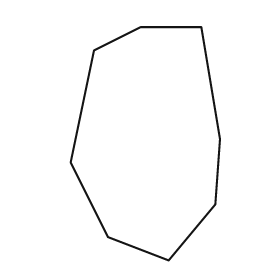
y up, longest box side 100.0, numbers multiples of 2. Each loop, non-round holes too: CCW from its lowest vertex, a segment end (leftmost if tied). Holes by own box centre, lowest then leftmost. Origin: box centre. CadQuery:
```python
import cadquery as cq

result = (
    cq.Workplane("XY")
    .moveTo(10.0, -50.0)
    .lineTo(30.0, -26.0)
    .lineTo(32.0, 2.0)
    .lineTo(24.0, 50.0)
    .lineTo(-2.0, 50.0)
    .lineTo(-22.0, 40.0)
    .lineTo(-32.0, -8.0)
    .lineTo(-16.0, -40.0)
    .close()
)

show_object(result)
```